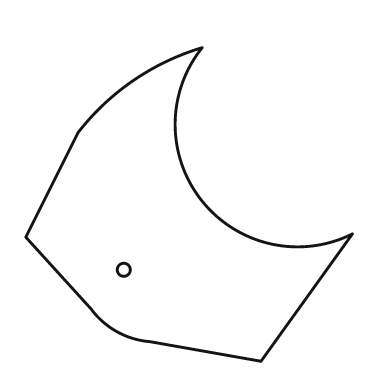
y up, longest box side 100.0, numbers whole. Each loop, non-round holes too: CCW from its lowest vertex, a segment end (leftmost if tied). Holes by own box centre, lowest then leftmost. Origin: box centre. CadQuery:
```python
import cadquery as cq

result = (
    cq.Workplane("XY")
    .moveTo(22.0, -48.0)
    .lineTo(50.0, -9.0)
    .threePointArc((4.0, 1.0), (4.0, 48.0))
    .threePointArc((-17.0, 38.0), (-34.0, 22.0))
    .lineTo(-50.0, -10.0)
    .lineTo(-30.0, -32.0)
    .threePointArc((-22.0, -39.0), (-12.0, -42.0))
    .close()
    .moveTo(-20.0, -20.0)
    .circle(2.0)
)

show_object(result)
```